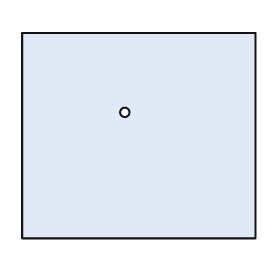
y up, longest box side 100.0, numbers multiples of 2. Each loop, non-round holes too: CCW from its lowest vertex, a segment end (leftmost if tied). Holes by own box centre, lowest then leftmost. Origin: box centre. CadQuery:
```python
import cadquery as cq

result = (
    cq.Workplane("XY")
    .moveTo(-50.0, -44.0)
    .lineTo(50.0, -44.0)
    .lineTo(50.0, 44.0)
    .lineTo(-50.0, 44.0)
    .close()
    .moveTo(-6.0, 10.0)
    .circle(2.0)
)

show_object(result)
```